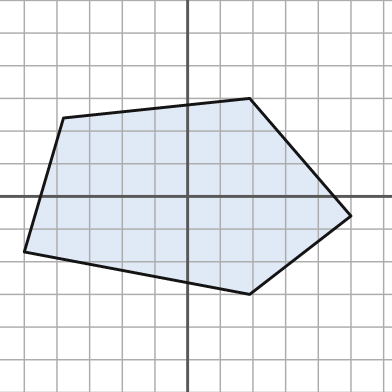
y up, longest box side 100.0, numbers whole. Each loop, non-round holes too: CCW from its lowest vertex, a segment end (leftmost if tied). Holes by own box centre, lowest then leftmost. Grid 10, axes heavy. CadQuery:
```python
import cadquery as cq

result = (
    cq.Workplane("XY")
    .moveTo(19.0, -30.0)
    .lineTo(50.0, -6.0)
    .lineTo(19.0, 30.0)
    .lineTo(-38.0, 24.0)
    .lineTo(-50.0, -17.0)
    .close()
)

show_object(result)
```